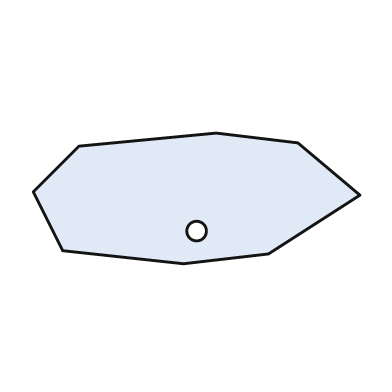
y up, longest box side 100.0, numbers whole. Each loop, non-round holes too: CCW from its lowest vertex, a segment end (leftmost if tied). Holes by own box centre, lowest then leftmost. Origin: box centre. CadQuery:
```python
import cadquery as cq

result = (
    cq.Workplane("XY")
    .moveTo(-4.0, -20.0)
    .lineTo(22.0, -17.0)
    .lineTo(50.0, 1.0)
    .lineTo(31.0, 17.0)
    .lineTo(6.0, 20.0)
    .lineTo(-36.0, 16.0)
    .lineTo(-50.0, 2.0)
    .lineTo(-41.0, -16.0)
    .close()
    .moveTo(0.0, -10.0)
    .circle(3.0)
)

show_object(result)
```